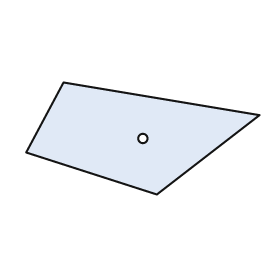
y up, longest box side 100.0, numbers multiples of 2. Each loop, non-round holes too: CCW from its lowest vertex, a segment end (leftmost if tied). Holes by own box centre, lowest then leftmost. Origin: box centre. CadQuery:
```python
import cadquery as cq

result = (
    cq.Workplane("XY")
    .moveTo(6.0, -24.0)
    .lineTo(50.0, 10.0)
    .lineTo(-34.0, 24.0)
    .lineTo(-50.0, -6.0)
    .close()
    .moveTo(0.0, 0.0)
    .circle(2.0)
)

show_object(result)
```